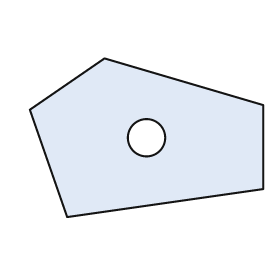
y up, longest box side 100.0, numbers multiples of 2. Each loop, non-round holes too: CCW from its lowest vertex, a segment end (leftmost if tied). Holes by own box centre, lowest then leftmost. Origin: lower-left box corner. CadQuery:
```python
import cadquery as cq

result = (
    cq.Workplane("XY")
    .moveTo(16.0, 0.0)
    .lineTo(100.0, 12.0)
    .lineTo(100.0, 48.0)
    .lineTo(32.0, 68.0)
    .lineTo(0.0, 46.0)
    .close()
    .moveTo(50.0, 34.0)
    .circle(8.0)
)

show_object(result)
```